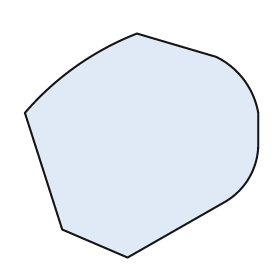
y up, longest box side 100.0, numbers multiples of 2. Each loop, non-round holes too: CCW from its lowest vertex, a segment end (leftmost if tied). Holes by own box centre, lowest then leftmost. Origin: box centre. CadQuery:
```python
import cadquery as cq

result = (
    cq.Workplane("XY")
    .moveTo(-6.0, -48.0)
    .lineTo(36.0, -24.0)
    .threePointArc((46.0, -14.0), (50.0, 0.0))
    .lineTo(50.0, 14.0)
    .threePointArc((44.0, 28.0), (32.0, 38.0))
    .lineTo(-2.0, 48.0)
    .threePointArc((-28.0, 34.0), (-50.0, 14.0))
    .lineTo(-34.0, -36.0)
    .close()
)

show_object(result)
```